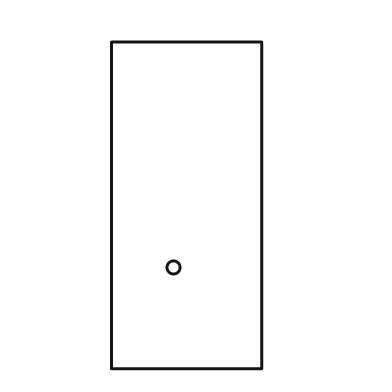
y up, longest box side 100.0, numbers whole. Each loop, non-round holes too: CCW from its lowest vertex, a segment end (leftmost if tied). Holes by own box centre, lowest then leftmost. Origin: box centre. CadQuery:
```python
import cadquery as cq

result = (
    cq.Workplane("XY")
    .moveTo(-23.0, -50.0)
    .lineTo(23.0, -50.0)
    .lineTo(23.0, 50.0)
    .lineTo(-23.0, 50.0)
    .close()
    .moveTo(-4.0, -19.0)
    .circle(2.0)
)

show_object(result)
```